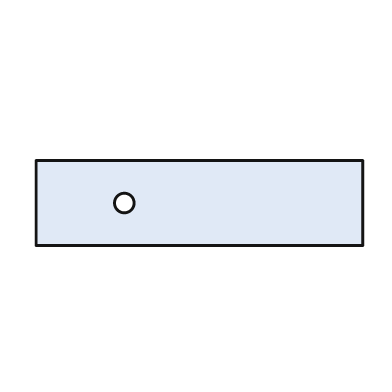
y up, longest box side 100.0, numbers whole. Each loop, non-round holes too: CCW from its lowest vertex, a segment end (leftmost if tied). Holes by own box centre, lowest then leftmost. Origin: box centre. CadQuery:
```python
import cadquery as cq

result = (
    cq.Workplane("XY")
    .moveTo(-50.0, -13.0)
    .lineTo(50.0, -13.0)
    .lineTo(50.0, 13.0)
    .lineTo(-50.0, 13.0)
    .close()
    .moveTo(-23.0, 0.0)
    .circle(3.0)
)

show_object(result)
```